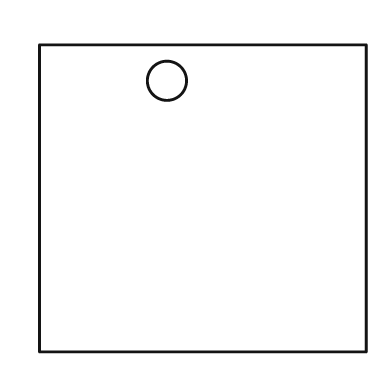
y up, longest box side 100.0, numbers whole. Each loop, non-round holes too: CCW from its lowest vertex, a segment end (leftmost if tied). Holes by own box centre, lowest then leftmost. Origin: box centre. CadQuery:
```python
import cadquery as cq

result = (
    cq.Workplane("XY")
    .moveTo(-50.0, -47.0)
    .lineTo(50.0, -47.0)
    .lineTo(50.0, 47.0)
    .lineTo(-50.0, 47.0)
    .close()
    .moveTo(-11.0, 36.0)
    .circle(6.0)
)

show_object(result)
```